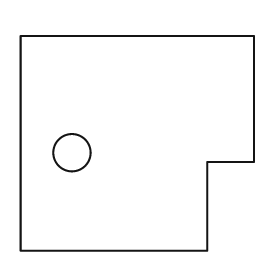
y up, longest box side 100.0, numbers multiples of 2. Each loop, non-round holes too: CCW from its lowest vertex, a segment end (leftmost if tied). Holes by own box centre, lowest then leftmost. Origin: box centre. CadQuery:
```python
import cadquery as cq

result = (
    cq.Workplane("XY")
    .moveTo(-50.0, -46.0)
    .lineTo(30.0, -46.0)
    .lineTo(30.0, -8.0)
    .lineTo(50.0, -8.0)
    .lineTo(50.0, 46.0)
    .lineTo(-50.0, 46.0)
    .close()
    .moveTo(-28.0, -4.0)
    .circle(8.0)
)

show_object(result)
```